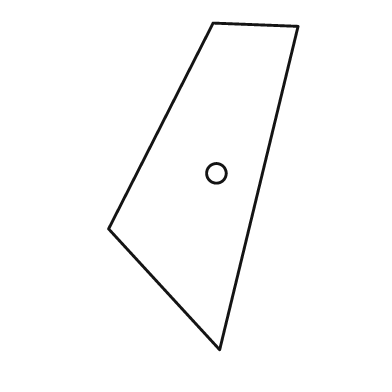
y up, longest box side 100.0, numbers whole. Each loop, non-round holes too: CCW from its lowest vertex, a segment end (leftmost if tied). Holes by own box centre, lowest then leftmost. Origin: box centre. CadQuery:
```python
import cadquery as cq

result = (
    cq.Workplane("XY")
    .moveTo(5.0, -50.0)
    .lineTo(29.0, 49.0)
    .lineTo(3.0, 50.0)
    .lineTo(-29.0, -13.0)
    .close()
    .moveTo(4.0, 4.0)
    .circle(3.0)
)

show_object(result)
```